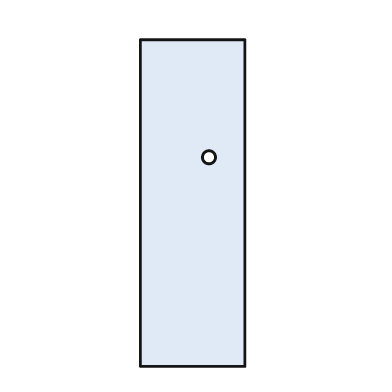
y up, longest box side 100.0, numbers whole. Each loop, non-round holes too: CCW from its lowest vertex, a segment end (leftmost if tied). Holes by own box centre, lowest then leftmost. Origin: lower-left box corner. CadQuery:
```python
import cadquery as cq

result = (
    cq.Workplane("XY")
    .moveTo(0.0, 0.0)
    .lineTo(32.0, 0.0)
    .lineTo(32.0, 100.0)
    .lineTo(0.0, 100.0)
    .close()
    .moveTo(21.0, 64.0)
    .circle(2.0)
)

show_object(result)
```